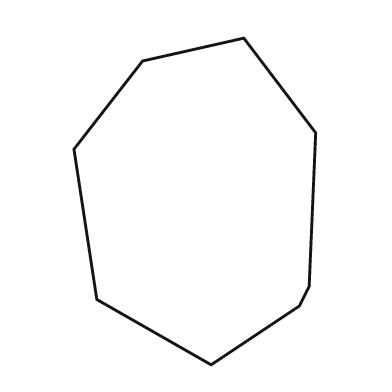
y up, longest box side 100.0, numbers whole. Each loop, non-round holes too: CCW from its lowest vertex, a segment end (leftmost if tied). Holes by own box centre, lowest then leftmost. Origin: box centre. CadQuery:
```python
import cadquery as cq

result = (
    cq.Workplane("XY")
    .moveTo(5.0, -50.0)
    .lineTo(32.0, -32.0)
    .lineTo(35.0, -26.0)
    .lineTo(37.0, 21.0)
    .lineTo(15.0, 50.0)
    .lineTo(-16.0, 43.0)
    .lineTo(-37.0, 16.0)
    .lineTo(-30.0, -30.0)
    .close()
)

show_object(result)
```